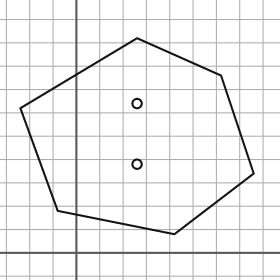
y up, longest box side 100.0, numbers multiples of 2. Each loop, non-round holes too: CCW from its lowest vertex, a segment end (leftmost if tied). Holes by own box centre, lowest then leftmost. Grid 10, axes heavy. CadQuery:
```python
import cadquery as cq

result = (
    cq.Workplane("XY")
    .moveTo(42.0, 8.0)
    .lineTo(76.0, 34.0)
    .lineTo(62.0, 76.0)
    .lineTo(26.0, 92.0)
    .lineTo(-24.0, 62.0)
    .lineTo(-8.0, 18.0)
    .close()
    .moveTo(26.0, 38.0)
    .circle(2.0)
    .moveTo(26.0, 64.0)
    .circle(2.0)
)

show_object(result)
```